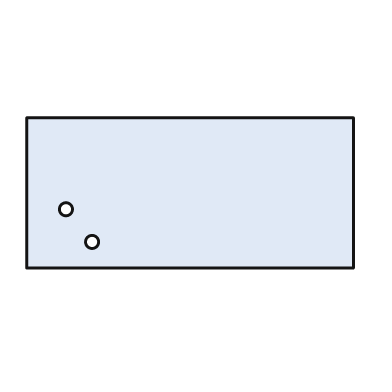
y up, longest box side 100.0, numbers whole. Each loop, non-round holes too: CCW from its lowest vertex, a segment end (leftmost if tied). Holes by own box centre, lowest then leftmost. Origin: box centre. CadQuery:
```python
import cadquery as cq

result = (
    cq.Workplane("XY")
    .moveTo(-50.0, -23.0)
    .lineTo(50.0, -23.0)
    .lineTo(50.0, 23.0)
    .lineTo(-50.0, 23.0)
    .close()
    .moveTo(-30.0, -15.0)
    .circle(2.0)
    .moveTo(-38.0, -5.0)
    .circle(2.0)
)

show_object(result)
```